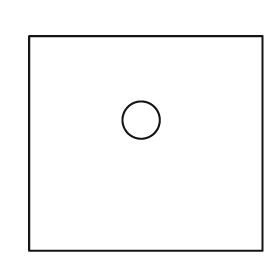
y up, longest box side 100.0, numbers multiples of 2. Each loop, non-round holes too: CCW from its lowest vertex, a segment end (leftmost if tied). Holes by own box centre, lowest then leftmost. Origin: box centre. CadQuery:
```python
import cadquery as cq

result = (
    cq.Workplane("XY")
    .moveTo(-50.0, -46.0)
    .lineTo(50.0, -46.0)
    .lineTo(50.0, 46.0)
    .lineTo(-50.0, 46.0)
    .close()
    .moveTo(-2.0, 10.0)
    .circle(8.0)
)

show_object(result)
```